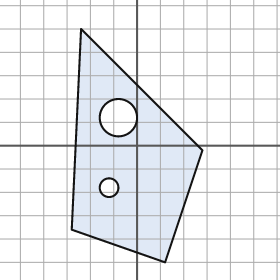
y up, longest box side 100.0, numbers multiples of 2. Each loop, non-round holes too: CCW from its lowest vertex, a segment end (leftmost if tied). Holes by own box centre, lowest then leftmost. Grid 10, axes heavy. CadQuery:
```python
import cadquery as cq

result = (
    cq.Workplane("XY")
    .moveTo(12.0, -50.0)
    .lineTo(28.0, -2.0)
    .lineTo(-24.0, 50.0)
    .lineTo(-28.0, -36.0)
    .close()
    .moveTo(-12.0, -18.0)
    .circle(4.0)
    .moveTo(-8.0, 12.0)
    .circle(8.0)
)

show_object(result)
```